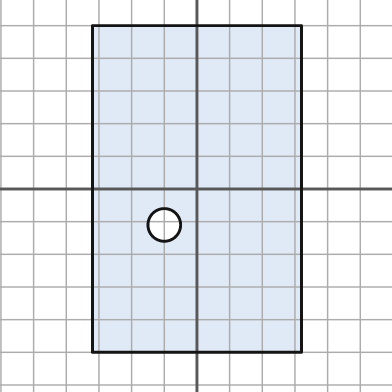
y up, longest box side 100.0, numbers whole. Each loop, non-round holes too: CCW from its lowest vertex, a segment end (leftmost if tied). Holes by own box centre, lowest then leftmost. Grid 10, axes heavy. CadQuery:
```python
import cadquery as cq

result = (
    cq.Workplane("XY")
    .moveTo(-32.0, -50.0)
    .lineTo(32.0, -50.0)
    .lineTo(32.0, 50.0)
    .lineTo(-32.0, 50.0)
    .close()
    .moveTo(-10.0, -11.0)
    .circle(5.0)
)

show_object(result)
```